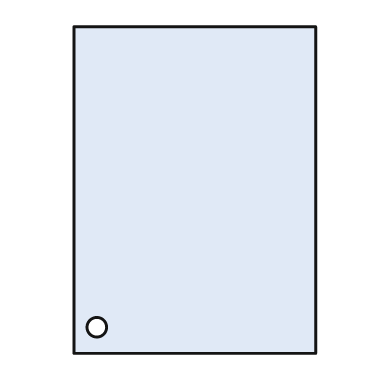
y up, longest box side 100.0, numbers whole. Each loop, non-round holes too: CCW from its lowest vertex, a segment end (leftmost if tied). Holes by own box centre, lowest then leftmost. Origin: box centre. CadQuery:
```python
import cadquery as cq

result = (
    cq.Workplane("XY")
    .moveTo(-37.0, -50.0)
    .lineTo(37.0, -50.0)
    .lineTo(37.0, 50.0)
    .lineTo(-37.0, 50.0)
    .close()
    .moveTo(-30.0, -42.0)
    .circle(3.0)
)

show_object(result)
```